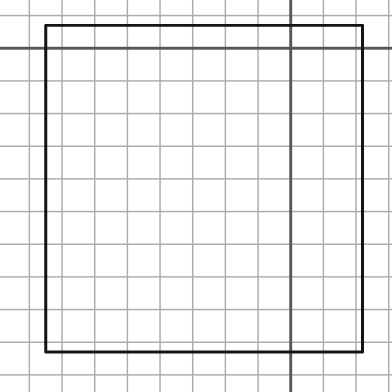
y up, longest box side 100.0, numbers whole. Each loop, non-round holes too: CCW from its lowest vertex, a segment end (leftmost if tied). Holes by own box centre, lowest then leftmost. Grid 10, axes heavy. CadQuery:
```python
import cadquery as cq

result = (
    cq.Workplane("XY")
    .moveTo(-75.0, -93.0)
    .lineTo(22.0, -93.0)
    .lineTo(22.0, 7.0)
    .lineTo(-75.0, 7.0)
    .close()
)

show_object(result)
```